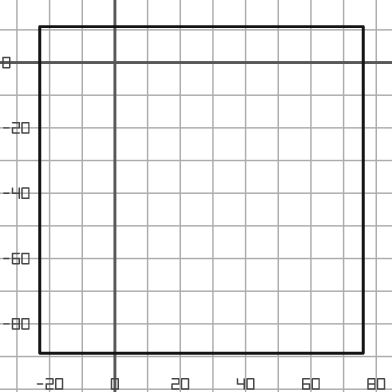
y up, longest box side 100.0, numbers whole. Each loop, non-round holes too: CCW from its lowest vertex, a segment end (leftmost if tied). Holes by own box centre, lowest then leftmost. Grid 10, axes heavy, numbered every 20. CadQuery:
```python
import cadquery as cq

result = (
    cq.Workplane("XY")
    .moveTo(-23.0, -89.0)
    .lineTo(76.0, -89.0)
    .lineTo(76.0, 11.0)
    .lineTo(-23.0, 11.0)
    .close()
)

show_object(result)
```